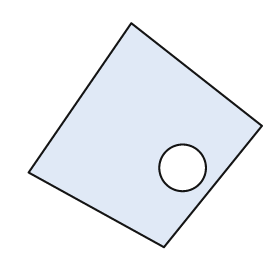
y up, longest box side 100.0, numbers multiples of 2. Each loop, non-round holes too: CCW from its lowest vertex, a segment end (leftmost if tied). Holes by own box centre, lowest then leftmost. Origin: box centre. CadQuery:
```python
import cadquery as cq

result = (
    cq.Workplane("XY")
    .moveTo(8.0, -48.0)
    .lineTo(50.0, 4.0)
    .lineTo(-6.0, 48.0)
    .lineTo(-50.0, -16.0)
    .close()
    .moveTo(16.0, -14.0)
    .circle(10.0)
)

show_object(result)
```